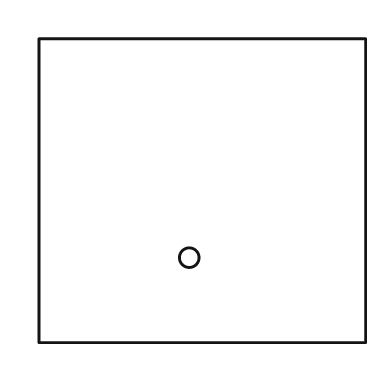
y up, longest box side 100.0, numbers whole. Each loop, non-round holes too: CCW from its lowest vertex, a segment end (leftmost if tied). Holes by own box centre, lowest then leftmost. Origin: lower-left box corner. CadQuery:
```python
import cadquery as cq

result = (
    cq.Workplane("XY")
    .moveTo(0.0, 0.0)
    .lineTo(100.0, 0.0)
    .lineTo(100.0, 93.0)
    .lineTo(0.0, 93.0)
    .close()
    .moveTo(46.0, 26.0)
    .circle(3.0)
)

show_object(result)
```